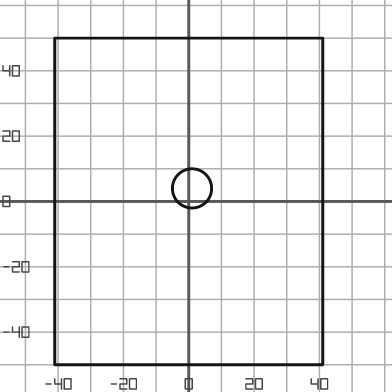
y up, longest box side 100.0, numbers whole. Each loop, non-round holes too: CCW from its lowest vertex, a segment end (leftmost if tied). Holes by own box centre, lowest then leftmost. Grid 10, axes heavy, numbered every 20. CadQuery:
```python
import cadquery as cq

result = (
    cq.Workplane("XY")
    .moveTo(-41.0, -50.0)
    .lineTo(41.0, -50.0)
    .lineTo(41.0, 50.0)
    .lineTo(-41.0, 50.0)
    .close()
    .moveTo(1.0, 4.0)
    .circle(6.0)
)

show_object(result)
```